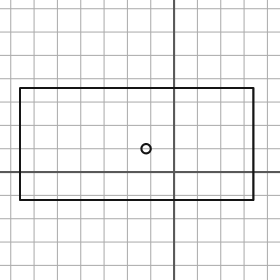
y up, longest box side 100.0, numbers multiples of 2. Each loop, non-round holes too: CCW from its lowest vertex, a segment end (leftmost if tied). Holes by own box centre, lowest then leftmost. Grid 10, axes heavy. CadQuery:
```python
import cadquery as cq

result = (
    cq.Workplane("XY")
    .moveTo(-66.0, -12.0)
    .lineTo(34.0, -12.0)
    .lineTo(34.0, 36.0)
    .lineTo(-66.0, 36.0)
    .close()
    .moveTo(-12.0, 10.0)
    .circle(2.0)
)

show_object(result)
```